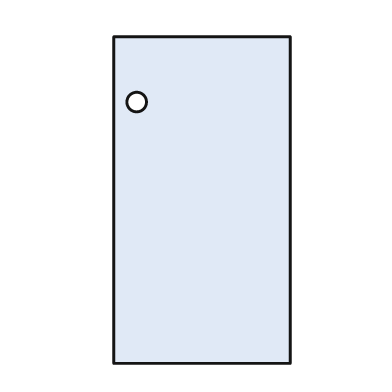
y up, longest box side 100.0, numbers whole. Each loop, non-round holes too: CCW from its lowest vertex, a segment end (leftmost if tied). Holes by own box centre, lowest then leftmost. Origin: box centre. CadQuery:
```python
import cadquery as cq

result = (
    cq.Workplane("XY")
    .moveTo(-27.0, -50.0)
    .lineTo(27.0, -50.0)
    .lineTo(27.0, 50.0)
    .lineTo(-27.0, 50.0)
    .close()
    .moveTo(-20.0, 30.0)
    .circle(3.0)
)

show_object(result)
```